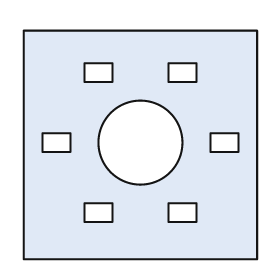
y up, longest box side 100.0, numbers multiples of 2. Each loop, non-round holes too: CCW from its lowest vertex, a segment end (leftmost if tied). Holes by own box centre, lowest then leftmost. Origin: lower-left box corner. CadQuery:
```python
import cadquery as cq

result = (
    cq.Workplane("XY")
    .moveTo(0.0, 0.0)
    .lineTo(100.0, 0.0)
    .lineTo(100.0, 98.0)
    .lineTo(0.0, 98.0)
    .close()
    .moveTo(26.0, 16.0)
    .lineTo(38.0, 16.0)
    .lineTo(38.0, 24.0)
    .lineTo(26.0, 24.0)
    .close()
    .moveTo(62.0, 16.0)
    .lineTo(74.0, 16.0)
    .lineTo(74.0, 24.0)
    .lineTo(62.0, 24.0)
    .close()
    .moveTo(8.0, 46.0)
    .lineTo(20.0, 46.0)
    .lineTo(20.0, 54.0)
    .lineTo(8.0, 54.0)
    .close()
    .moveTo(50.0, 50.0)
    .circle(18.0)
    .moveTo(80.0, 46.0)
    .lineTo(92.0, 46.0)
    .lineTo(92.0, 54.0)
    .lineTo(80.0, 54.0)
    .close()
    .moveTo(26.0, 76.0)
    .lineTo(38.0, 76.0)
    .lineTo(38.0, 84.0)
    .lineTo(26.0, 84.0)
    .close()
    .moveTo(62.0, 76.0)
    .lineTo(74.0, 76.0)
    .lineTo(74.0, 84.0)
    .lineTo(62.0, 84.0)
    .close()
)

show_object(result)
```